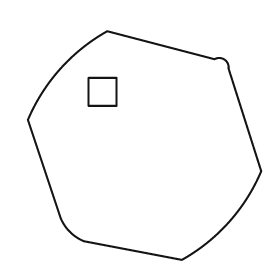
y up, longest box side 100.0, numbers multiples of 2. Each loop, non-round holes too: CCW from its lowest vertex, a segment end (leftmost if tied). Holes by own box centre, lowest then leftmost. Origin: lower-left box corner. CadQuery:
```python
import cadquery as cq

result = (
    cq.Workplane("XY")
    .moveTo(66.0, 0.0)
    .threePointArc((86.0, 16.0), (100.0, 38.0))
    .lineTo(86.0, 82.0)
    .threePointArc((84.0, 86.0), (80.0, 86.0))
    .lineTo(34.0, 98.0)
    .threePointArc((14.0, 82.0), (0.0, 60.0))
    .lineTo(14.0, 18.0)
    .threePointArc((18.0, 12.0), (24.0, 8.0))
    .close()
    .moveTo(26.0, 66.0)
    .lineTo(38.0, 66.0)
    .lineTo(38.0, 78.0)
    .lineTo(26.0, 78.0)
    .close()
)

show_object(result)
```